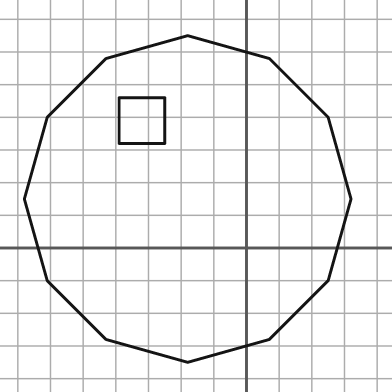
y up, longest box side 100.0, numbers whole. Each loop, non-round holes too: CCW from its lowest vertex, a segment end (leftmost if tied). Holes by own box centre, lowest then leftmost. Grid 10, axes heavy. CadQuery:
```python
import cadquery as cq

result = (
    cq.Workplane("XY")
    .moveTo(-18.0, -35.0)
    .lineTo(7.0, -28.0)
    .lineTo(25.0, -10.0)
    .lineTo(32.0, 15.0)
    .lineTo(25.0, 40.0)
    .lineTo(7.0, 58.0)
    .lineTo(-18.0, 65.0)
    .lineTo(-43.0, 58.0)
    .lineTo(-61.0, 40.0)
    .lineTo(-68.0, 15.0)
    .lineTo(-61.0, -10.0)
    .lineTo(-43.0, -28.0)
    .close()
    .moveTo(-39.0, 32.0)
    .lineTo(-25.0, 32.0)
    .lineTo(-25.0, 46.0)
    .lineTo(-39.0, 46.0)
    .close()
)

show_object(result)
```